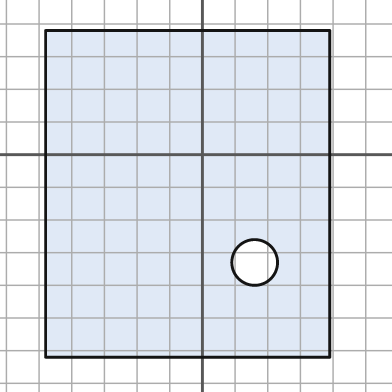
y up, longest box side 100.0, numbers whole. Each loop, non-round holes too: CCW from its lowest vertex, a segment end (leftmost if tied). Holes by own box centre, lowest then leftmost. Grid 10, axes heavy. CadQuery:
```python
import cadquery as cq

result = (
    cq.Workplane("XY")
    .moveTo(-48.0, -62.0)
    .lineTo(39.0, -62.0)
    .lineTo(39.0, 38.0)
    .lineTo(-48.0, 38.0)
    .close()
    .moveTo(16.0, -33.0)
    .circle(7.0)
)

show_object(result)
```